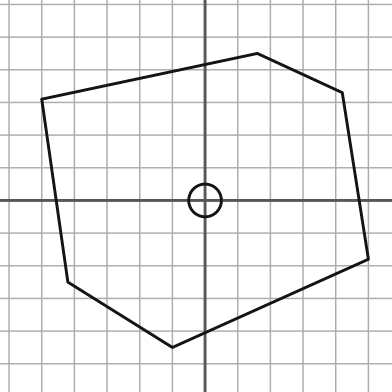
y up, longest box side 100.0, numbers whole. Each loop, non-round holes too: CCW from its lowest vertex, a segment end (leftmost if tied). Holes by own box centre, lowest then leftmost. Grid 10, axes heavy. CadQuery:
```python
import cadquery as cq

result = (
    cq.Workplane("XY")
    .moveTo(-10.0, -45.0)
    .lineTo(50.0, -18.0)
    .lineTo(42.0, 33.0)
    .lineTo(16.0, 45.0)
    .lineTo(-50.0, 31.0)
    .lineTo(-42.0, -25.0)
    .close()
    .moveTo(0.0, 0.0)
    .circle(5.0)
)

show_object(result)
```